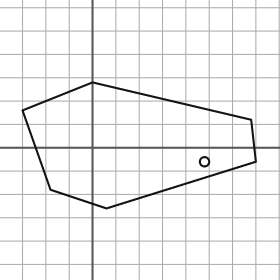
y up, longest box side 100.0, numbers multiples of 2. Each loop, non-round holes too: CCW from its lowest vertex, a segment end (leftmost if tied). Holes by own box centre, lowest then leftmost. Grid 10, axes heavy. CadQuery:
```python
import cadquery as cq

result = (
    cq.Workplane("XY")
    .moveTo(6.0, -26.0)
    .lineTo(70.0, -6.0)
    .lineTo(68.0, 12.0)
    .lineTo(0.0, 28.0)
    .lineTo(-30.0, 16.0)
    .lineTo(-18.0, -18.0)
    .close()
    .moveTo(48.0, -6.0)
    .circle(2.0)
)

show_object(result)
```